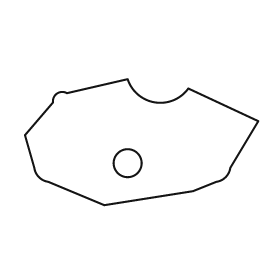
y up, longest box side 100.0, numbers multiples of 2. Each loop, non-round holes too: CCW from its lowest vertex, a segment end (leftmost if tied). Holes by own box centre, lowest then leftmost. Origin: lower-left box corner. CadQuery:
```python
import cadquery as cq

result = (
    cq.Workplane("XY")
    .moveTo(34.0, 0.0)
    .lineTo(72.0, 6.0)
    .lineTo(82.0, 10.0)
    .threePointArc((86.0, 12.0), (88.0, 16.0))
    .lineTo(100.0, 36.0)
    .lineTo(70.0, 50.0)
    .threePointArc((56.0, 44.0), (44.0, 54.0))
    .lineTo(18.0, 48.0)
    .threePointArc((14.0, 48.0), (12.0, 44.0))
    .lineTo(0.0, 30.0)
    .lineTo(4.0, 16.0)
    .threePointArc((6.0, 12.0), (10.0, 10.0))
    .close()
    .moveTo(44.0, 18.0)
    .circle(6.0)
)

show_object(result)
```